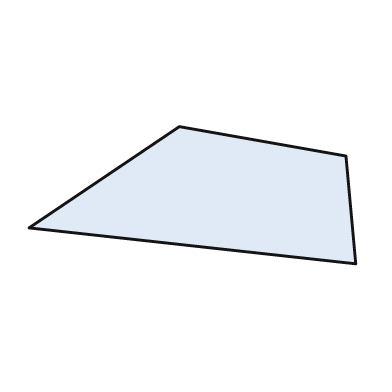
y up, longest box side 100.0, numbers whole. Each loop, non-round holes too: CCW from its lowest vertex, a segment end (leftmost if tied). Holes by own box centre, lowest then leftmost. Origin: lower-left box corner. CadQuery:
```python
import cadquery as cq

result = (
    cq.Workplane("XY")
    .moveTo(100.0, 0.0)
    .lineTo(97.0, 33.0)
    .lineTo(46.0, 42.0)
    .lineTo(0.0, 11.0)
    .close()
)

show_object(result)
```